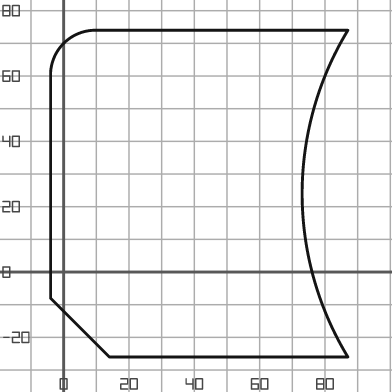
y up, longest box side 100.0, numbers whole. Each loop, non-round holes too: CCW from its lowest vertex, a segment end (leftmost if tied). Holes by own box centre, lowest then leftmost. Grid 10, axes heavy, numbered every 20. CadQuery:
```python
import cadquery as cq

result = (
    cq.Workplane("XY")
    .moveTo(14.0, -26.0)
    .lineTo(87.0, -26.0)
    .threePointArc((73.0, 24.0), (87.0, 74.0))
    .lineTo(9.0, 74.0)
    .threePointArc((0.0, 70.0), (-4.0, 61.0))
    .lineTo(-4.0, -8.0)
    .close()
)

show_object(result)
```